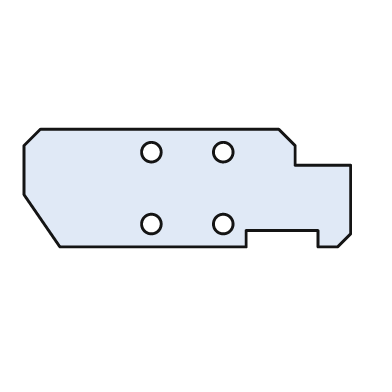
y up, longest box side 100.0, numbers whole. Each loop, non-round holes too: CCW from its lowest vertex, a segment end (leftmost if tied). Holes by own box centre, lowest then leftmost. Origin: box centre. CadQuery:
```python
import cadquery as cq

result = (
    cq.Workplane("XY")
    .moveTo(-39.0, -18.0)
    .lineTo(18.0, -18.0)
    .lineTo(18.0, -13.0)
    .lineTo(40.0, -13.0)
    .lineTo(40.0, -18.0)
    .lineTo(46.0, -18.0)
    .lineTo(50.0, -14.0)
    .lineTo(50.0, 7.0)
    .lineTo(33.0, 7.0)
    .lineTo(33.0, 13.0)
    .lineTo(28.0, 18.0)
    .lineTo(-45.0, 18.0)
    .lineTo(-50.0, 13.0)
    .lineTo(-50.0, -2.0)
    .close()
    .moveTo(-11.0, -11.0)
    .circle(3.0)
    .moveTo(11.0, -11.0)
    .circle(3.0)
    .moveTo(-11.0, 11.0)
    .circle(3.0)
    .moveTo(11.0, 11.0)
    .circle(3.0)
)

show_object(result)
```